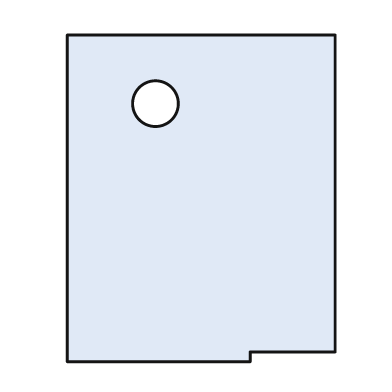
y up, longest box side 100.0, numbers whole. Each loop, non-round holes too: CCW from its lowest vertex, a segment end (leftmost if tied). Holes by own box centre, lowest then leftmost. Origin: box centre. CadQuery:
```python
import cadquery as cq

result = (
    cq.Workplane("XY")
    .moveTo(-41.0, -50.0)
    .lineTo(15.0, -50.0)
    .lineTo(15.0, -47.0)
    .lineTo(41.0, -47.0)
    .lineTo(41.0, 50.0)
    .lineTo(-41.0, 50.0)
    .close()
    .moveTo(-14.0, 29.0)
    .circle(7.0)
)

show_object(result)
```